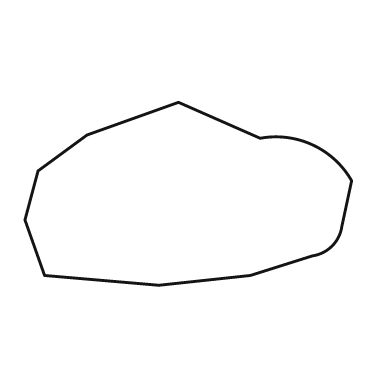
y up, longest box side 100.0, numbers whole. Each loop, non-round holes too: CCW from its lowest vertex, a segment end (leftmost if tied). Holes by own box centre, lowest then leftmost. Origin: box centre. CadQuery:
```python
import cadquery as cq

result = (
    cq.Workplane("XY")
    .moveTo(-9.0, -28.0)
    .lineTo(19.0, -25.0)
    .lineTo(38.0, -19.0)
    .threePointArc((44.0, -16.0), (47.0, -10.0))
    .lineTo(50.0, 4.0)
    .threePointArc((38.0, 15.0), (22.0, 17.0))
    .lineTo(-3.0, 28.0)
    .lineTo(-31.0, 18.0)
    .lineTo(-46.0, 7.0)
    .lineTo(-50.0, -8.0)
    .lineTo(-44.0, -25.0)
    .close()
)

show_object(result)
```